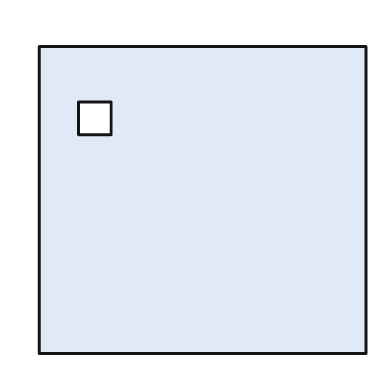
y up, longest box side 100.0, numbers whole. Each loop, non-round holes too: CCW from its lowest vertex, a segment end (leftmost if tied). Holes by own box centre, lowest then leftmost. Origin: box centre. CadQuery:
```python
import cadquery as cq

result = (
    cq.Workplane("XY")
    .moveTo(-50.0, -47.0)
    .lineTo(50.0, -47.0)
    .lineTo(50.0, 47.0)
    .lineTo(-50.0, 47.0)
    .close()
    .moveTo(-38.0, 20.0)
    .lineTo(-28.0, 20.0)
    .lineTo(-28.0, 30.0)
    .lineTo(-38.0, 30.0)
    .close()
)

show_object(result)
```